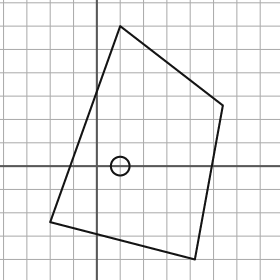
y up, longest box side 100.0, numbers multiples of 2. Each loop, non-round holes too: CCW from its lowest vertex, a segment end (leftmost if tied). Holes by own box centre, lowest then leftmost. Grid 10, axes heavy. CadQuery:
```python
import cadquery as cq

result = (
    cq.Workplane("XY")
    .moveTo(42.0, -40.0)
    .lineTo(54.0, 26.0)
    .lineTo(10.0, 60.0)
    .lineTo(-20.0, -24.0)
    .close()
    .moveTo(10.0, 0.0)
    .circle(4.0)
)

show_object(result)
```